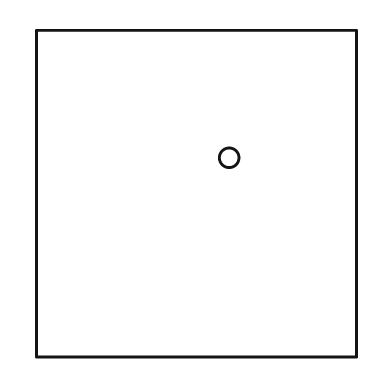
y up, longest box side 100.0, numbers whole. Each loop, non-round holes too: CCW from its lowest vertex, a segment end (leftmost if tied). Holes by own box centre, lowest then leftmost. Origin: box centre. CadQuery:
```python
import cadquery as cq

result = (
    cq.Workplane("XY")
    .moveTo(-49.0, -50.0)
    .lineTo(49.0, -50.0)
    .lineTo(49.0, 50.0)
    .lineTo(-49.0, 50.0)
    .close()
    .moveTo(10.0, 11.0)
    .circle(3.0)
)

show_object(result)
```